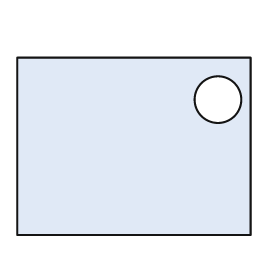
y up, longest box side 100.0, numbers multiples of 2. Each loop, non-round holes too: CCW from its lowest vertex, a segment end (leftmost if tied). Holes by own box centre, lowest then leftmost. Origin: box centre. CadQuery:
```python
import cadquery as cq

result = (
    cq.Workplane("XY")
    .moveTo(-50.0, -38.0)
    .lineTo(50.0, -38.0)
    .lineTo(50.0, 38.0)
    .lineTo(-50.0, 38.0)
    .close()
    .moveTo(36.0, 20.0)
    .circle(10.0)
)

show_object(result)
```